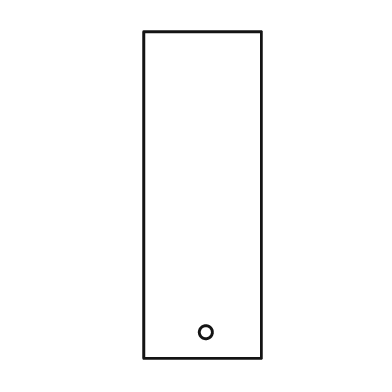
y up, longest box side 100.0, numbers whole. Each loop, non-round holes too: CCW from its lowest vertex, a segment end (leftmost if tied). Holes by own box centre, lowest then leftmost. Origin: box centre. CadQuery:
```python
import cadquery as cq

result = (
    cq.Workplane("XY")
    .moveTo(-18.0, -50.0)
    .lineTo(18.0, -50.0)
    .lineTo(18.0, 50.0)
    .lineTo(-18.0, 50.0)
    .close()
    .moveTo(1.0, -42.0)
    .circle(2.0)
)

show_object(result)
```